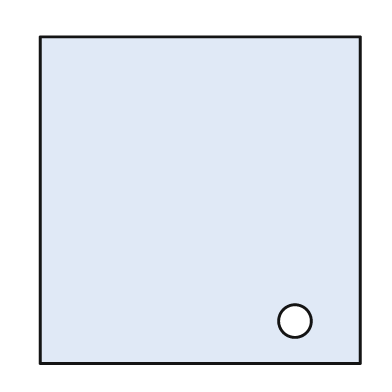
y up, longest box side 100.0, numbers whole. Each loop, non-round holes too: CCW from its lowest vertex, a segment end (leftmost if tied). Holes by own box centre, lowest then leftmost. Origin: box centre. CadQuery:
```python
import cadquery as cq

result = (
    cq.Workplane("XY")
    .moveTo(-49.0, -50.0)
    .lineTo(49.0, -50.0)
    .lineTo(49.0, 50.0)
    .lineTo(-49.0, 50.0)
    .close()
    .moveTo(29.0, -37.0)
    .circle(5.0)
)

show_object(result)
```